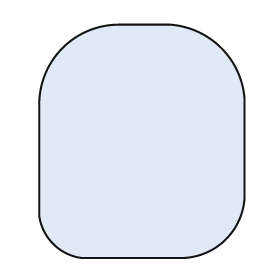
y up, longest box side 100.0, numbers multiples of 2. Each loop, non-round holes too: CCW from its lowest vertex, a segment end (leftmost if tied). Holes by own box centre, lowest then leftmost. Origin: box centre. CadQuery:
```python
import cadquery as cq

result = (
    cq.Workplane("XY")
    .moveTo(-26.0, -50.0)
    .lineTo(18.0, -50.0)
    .threePointArc((36.0, -42.0), (44.0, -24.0))
    .lineTo(44.0, 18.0)
    .threePointArc((34.0, 40.0), (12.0, 50.0))
    .lineTo(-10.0, 50.0)
    .threePointArc((-34.0, 40.0), (-44.0, 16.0))
    .lineTo(-44.0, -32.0)
    .threePointArc((-38.0, -44.0), (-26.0, -50.0))
    .close()
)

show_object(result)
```